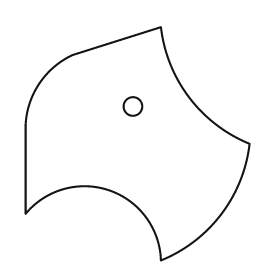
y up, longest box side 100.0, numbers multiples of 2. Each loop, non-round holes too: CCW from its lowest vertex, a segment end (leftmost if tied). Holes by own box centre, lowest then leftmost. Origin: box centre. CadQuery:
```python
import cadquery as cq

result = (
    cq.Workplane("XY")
    .moveTo(10.0, -50.0)
    .threePointArc((36.0, -30.0), (48.0, 0.0))
    .threePointArc((22.0, 20.0), (10.0, 50.0))
    .lineTo(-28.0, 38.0)
    .threePointArc((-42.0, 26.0), (-48.0, 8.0))
    .lineTo(-48.0, -30.0)
    .threePointArc((-12.0, -20.0), (10.0, -50.0))
    .close()
    .moveTo(-2.0, 16.0)
    .circle(4.0)
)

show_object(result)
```